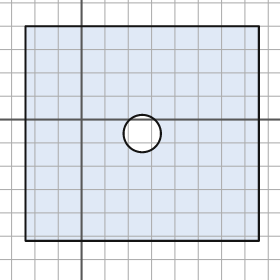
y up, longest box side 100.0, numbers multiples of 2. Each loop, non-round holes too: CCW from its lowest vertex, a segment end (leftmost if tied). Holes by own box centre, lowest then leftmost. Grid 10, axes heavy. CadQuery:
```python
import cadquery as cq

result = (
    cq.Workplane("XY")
    .moveTo(-24.0, -52.0)
    .lineTo(76.0, -52.0)
    .lineTo(76.0, 40.0)
    .lineTo(-24.0, 40.0)
    .close()
    .moveTo(26.0, -6.0)
    .circle(8.0)
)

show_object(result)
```